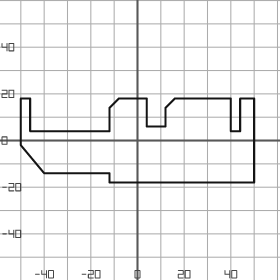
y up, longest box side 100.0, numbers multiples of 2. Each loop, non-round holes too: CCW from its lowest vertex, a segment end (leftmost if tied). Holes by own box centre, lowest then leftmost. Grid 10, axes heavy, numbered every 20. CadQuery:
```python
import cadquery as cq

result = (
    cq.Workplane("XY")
    .moveTo(-12.0, -18.0)
    .lineTo(50.0, -18.0)
    .lineTo(50.0, 18.0)
    .lineTo(44.0, 18.0)
    .lineTo(44.0, 4.0)
    .lineTo(40.0, 4.0)
    .lineTo(40.0, 18.0)
    .lineTo(16.0, 18.0)
    .lineTo(12.0, 14.0)
    .lineTo(12.0, 6.0)
    .lineTo(4.0, 6.0)
    .lineTo(4.0, 18.0)
    .lineTo(-8.0, 18.0)
    .lineTo(-12.0, 14.0)
    .lineTo(-12.0, 4.0)
    .lineTo(-46.0, 4.0)
    .lineTo(-46.0, 18.0)
    .lineTo(-50.0, 18.0)
    .lineTo(-50.0, -2.0)
    .lineTo(-40.0, -14.0)
    .lineTo(-12.0, -14.0)
    .close()
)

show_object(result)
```